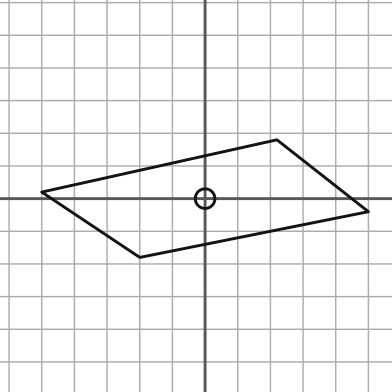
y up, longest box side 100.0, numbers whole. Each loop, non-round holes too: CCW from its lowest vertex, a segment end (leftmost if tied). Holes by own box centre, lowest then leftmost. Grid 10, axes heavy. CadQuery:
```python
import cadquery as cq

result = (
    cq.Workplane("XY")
    .moveTo(-20.0, -18.0)
    .lineTo(50.0, -4.0)
    .lineTo(22.0, 18.0)
    .lineTo(-50.0, 2.0)
    .close()
    .moveTo(0.0, 0.0)
    .circle(3.0)
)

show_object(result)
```